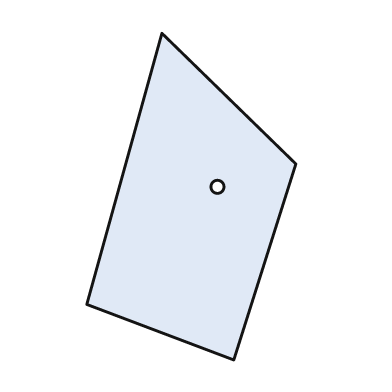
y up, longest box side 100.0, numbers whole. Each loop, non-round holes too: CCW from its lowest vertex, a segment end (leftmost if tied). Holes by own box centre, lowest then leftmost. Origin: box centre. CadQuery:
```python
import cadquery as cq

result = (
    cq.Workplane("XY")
    .moveTo(13.0, -50.0)
    .lineTo(32.0, 10.0)
    .lineTo(-9.0, 50.0)
    .lineTo(-32.0, -33.0)
    .close()
    .moveTo(8.0, 3.0)
    .circle(2.0)
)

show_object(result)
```